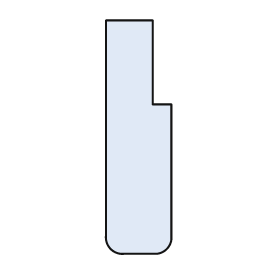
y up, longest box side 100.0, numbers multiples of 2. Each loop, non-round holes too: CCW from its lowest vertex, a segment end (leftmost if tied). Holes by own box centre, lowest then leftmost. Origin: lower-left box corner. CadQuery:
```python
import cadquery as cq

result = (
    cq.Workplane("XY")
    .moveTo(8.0, 0.0)
    .lineTo(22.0, 0.0)
    .threePointArc((26.0, 2.0), (28.0, 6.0))
    .lineTo(28.0, 64.0)
    .lineTo(20.0, 64.0)
    .lineTo(20.0, 100.0)
    .lineTo(0.0, 100.0)
    .lineTo(0.0, 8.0)
    .threePointArc((2.0, 2.0), (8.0, 0.0))
    .close()
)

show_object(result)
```